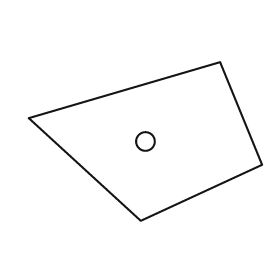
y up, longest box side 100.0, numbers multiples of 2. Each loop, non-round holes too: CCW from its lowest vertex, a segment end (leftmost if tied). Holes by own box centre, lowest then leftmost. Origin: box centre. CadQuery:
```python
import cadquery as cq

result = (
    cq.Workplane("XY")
    .moveTo(-2.0, -34.0)
    .lineTo(50.0, -10.0)
    .lineTo(32.0, 34.0)
    .lineTo(-50.0, 10.0)
    .close()
    .moveTo(0.0, 0.0)
    .circle(4.0)
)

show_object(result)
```